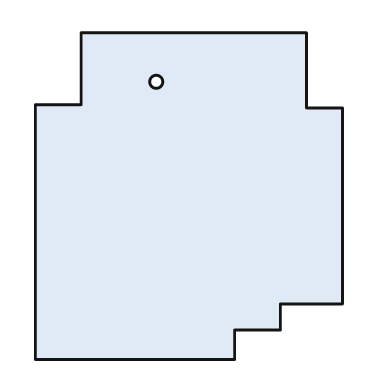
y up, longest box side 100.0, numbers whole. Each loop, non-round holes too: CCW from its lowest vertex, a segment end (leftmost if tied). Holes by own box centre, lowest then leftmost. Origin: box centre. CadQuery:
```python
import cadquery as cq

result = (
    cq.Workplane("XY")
    .moveTo(-47.0, -50.0)
    .lineTo(14.0, -50.0)
    .lineTo(14.0, -41.0)
    .lineTo(28.0, -41.0)
    .lineTo(28.0, -33.0)
    .lineTo(47.0, -33.0)
    .lineTo(47.0, 27.0)
    .lineTo(36.0, 27.0)
    .lineTo(36.0, 50.0)
    .lineTo(-33.0, 50.0)
    .lineTo(-33.0, 28.0)
    .lineTo(-47.0, 28.0)
    .close()
    .moveTo(-10.0, 35.0)
    .circle(2.0)
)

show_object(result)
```